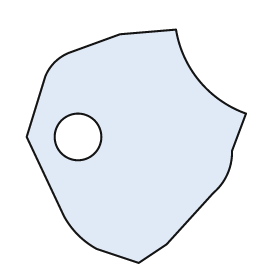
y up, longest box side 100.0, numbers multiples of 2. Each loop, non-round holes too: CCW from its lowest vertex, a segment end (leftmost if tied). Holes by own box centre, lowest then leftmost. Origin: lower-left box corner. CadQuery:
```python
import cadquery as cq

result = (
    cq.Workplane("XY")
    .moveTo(48.0, 0.0)
    .lineTo(60.0, 8.0)
    .lineTo(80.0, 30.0)
    .threePointArc((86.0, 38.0), (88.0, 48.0))
    .lineTo(94.0, 64.0)
    .threePointArc((74.0, 78.0), (64.0, 100.0))
    .lineTo(40.0, 98.0)
    .lineTo(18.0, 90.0)
    .threePointArc((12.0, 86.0), (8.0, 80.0))
    .lineTo(0.0, 54.0)
    .lineTo(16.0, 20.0)
    .threePointArc((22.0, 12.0), (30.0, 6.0))
    .close()
    .moveTo(22.0, 54.0)
    .circle(10.0)
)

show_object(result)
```